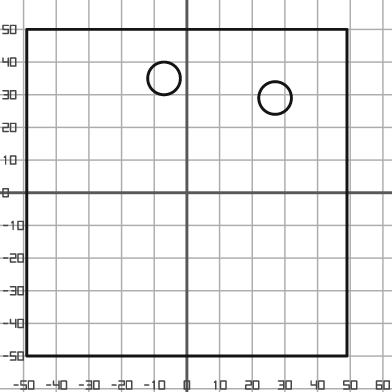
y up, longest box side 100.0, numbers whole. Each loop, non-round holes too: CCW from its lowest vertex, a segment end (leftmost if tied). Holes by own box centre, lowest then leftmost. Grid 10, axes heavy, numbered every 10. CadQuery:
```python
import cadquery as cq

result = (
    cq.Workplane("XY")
    .moveTo(-49.0, -50.0)
    .lineTo(49.0, -50.0)
    .lineTo(49.0, 50.0)
    .lineTo(-49.0, 50.0)
    .close()
    .moveTo(27.0, 29.0)
    .circle(5.0)
    .moveTo(-7.0, 35.0)
    .circle(5.0)
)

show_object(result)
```